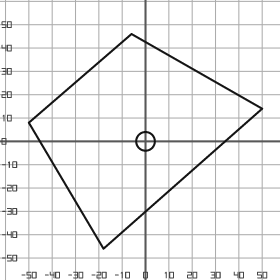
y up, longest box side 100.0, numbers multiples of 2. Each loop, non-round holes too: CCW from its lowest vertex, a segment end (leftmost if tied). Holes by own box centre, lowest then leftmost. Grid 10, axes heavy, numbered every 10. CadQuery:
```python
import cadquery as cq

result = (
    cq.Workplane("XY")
    .moveTo(-18.0, -46.0)
    .lineTo(50.0, 14.0)
    .lineTo(-6.0, 46.0)
    .lineTo(-50.0, 8.0)
    .close()
    .moveTo(0.0, 0.0)
    .circle(4.0)
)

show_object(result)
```